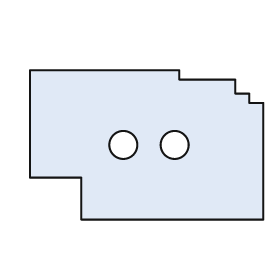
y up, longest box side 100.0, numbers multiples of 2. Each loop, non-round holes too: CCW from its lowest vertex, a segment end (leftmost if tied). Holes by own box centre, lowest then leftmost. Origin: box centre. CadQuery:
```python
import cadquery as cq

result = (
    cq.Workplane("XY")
    .moveTo(-28.0, -32.0)
    .lineTo(50.0, -32.0)
    .lineTo(50.0, 18.0)
    .lineTo(44.0, 18.0)
    .lineTo(44.0, 22.0)
    .lineTo(38.0, 22.0)
    .lineTo(38.0, 28.0)
    .lineTo(14.0, 28.0)
    .lineTo(14.0, 32.0)
    .lineTo(-50.0, 32.0)
    .lineTo(-50.0, -14.0)
    .lineTo(-28.0, -14.0)
    .close()
    .moveTo(-10.0, 0.0)
    .circle(6.0)
    .moveTo(12.0, 0.0)
    .circle(6.0)
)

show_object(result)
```